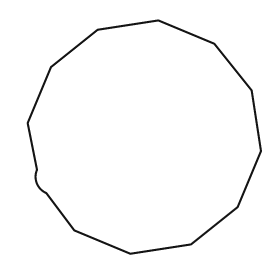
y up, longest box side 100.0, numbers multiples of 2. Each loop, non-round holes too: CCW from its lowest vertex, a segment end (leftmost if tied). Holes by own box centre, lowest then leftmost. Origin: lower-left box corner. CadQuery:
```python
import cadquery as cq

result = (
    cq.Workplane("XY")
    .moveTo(44.0, 0.0)
    .lineTo(70.0, 4.0)
    .lineTo(90.0, 20.0)
    .lineTo(100.0, 44.0)
    .lineTo(96.0, 70.0)
    .lineTo(80.0, 90.0)
    .lineTo(56.0, 100.0)
    .lineTo(30.0, 96.0)
    .lineTo(10.0, 80.0)
    .lineTo(0.0, 56.0)
    .lineTo(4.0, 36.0)
    .threePointArc((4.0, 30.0), (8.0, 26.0))
    .lineTo(20.0, 10.0)
    .close()
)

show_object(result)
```